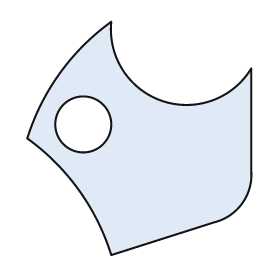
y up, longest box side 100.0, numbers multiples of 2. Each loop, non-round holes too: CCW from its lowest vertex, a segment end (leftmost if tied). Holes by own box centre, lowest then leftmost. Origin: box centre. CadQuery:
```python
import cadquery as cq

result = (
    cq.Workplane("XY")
    .moveTo(-12.0, -50.0)
    .lineTo(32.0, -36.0)
    .threePointArc((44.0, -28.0), (48.0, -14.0))
    .lineTo(48.0, 30.0)
    .threePointArc((10.0, 16.0), (-12.0, 50.0))
    .threePointArc((-34.0, 28.0), (-48.0, 0.0))
    .threePointArc((-26.0, -22.0), (-12.0, -50.0))
    .close()
    .moveTo(-24.0, 6.0)
    .circle(12.0)
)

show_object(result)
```